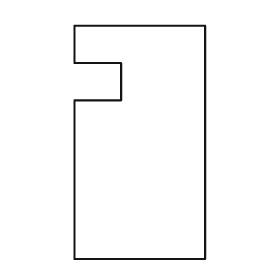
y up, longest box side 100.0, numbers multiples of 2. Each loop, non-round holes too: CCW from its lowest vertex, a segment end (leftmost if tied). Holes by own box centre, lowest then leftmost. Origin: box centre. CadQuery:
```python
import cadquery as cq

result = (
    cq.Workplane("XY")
    .moveTo(-28.0, -50.0)
    .lineTo(28.0, -50.0)
    .lineTo(28.0, 50.0)
    .lineTo(-28.0, 50.0)
    .lineTo(-28.0, 34.0)
    .lineTo(-8.0, 34.0)
    .lineTo(-8.0, 18.0)
    .lineTo(-28.0, 18.0)
    .close()
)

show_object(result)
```